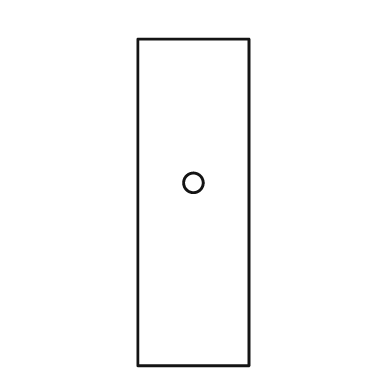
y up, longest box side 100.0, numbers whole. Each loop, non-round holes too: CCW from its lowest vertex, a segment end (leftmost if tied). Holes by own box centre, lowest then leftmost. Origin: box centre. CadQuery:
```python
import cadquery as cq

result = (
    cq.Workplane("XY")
    .moveTo(-17.0, -50.0)
    .lineTo(17.0, -50.0)
    .lineTo(17.0, 50.0)
    .lineTo(-17.0, 50.0)
    .close()
    .moveTo(0.0, 6.0)
    .circle(3.0)
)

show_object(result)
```